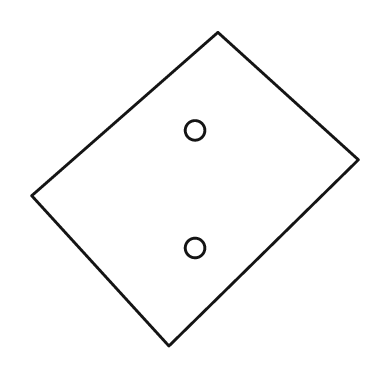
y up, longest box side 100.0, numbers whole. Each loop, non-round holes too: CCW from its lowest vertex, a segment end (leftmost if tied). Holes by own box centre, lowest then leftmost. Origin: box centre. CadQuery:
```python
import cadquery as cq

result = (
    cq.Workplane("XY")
    .moveTo(-8.0, -48.0)
    .lineTo(50.0, 9.0)
    .lineTo(7.0, 48.0)
    .lineTo(-50.0, -2.0)
    .close()
    .moveTo(0.0, -18.0)
    .circle(3.0)
    .moveTo(0.0, 18.0)
    .circle(3.0)
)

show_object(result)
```